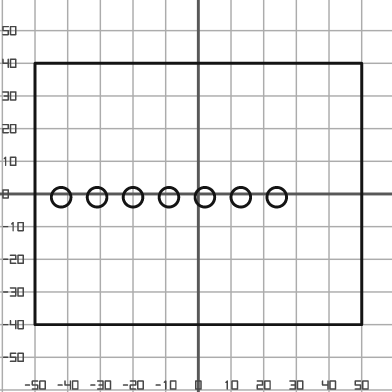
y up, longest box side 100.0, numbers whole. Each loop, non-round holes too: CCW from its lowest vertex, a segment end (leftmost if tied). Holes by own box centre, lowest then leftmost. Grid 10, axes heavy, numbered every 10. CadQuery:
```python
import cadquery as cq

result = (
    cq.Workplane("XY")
    .moveTo(-50.0, -40.0)
    .lineTo(50.0, -40.0)
    .lineTo(50.0, 40.0)
    .lineTo(-50.0, 40.0)
    .close()
    .moveTo(-42.0, -1.0)
    .circle(3.0)
    .moveTo(-31.0, -1.0)
    .circle(3.0)
    .moveTo(-20.0, -1.0)
    .circle(3.0)
    .moveTo(-9.0, -1.0)
    .circle(3.0)
    .moveTo(2.0, -1.0)
    .circle(3.0)
    .moveTo(13.0, -1.0)
    .circle(3.0)
    .moveTo(24.0, -1.0)
    .circle(3.0)
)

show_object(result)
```